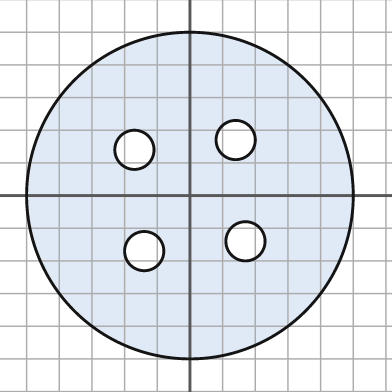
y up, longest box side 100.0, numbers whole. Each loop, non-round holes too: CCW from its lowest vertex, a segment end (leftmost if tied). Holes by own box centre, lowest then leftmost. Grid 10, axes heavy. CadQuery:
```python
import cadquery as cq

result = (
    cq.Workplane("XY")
    .moveTo(0.0, 0.0)
    .circle(50.0)
    .moveTo(-14.0, -17.0)
    .circle(6.0)
    .moveTo(17.0, -14.0)
    .circle(6.0)
    .moveTo(-17.0, 14.0)
    .circle(6.0)
    .moveTo(14.0, 17.0)
    .circle(6.0)
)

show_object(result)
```